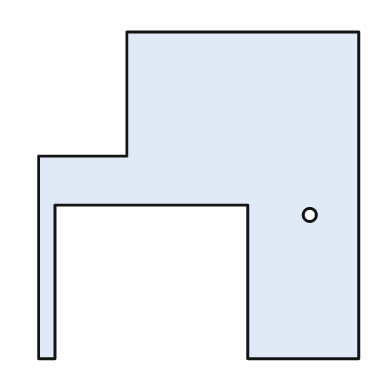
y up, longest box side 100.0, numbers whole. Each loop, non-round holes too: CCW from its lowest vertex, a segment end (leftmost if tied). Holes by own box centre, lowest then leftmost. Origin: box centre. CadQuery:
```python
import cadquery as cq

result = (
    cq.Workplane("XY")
    .moveTo(-49.0, -50.0)
    .lineTo(-44.0, -50.0)
    .lineTo(-44.0, -3.0)
    .lineTo(15.0, -3.0)
    .lineTo(15.0, -50.0)
    .lineTo(49.0, -50.0)
    .lineTo(49.0, 50.0)
    .lineTo(-22.0, 50.0)
    .lineTo(-22.0, 12.0)
    .lineTo(-49.0, 12.0)
    .close()
    .moveTo(34.0, -6.0)
    .circle(2.0)
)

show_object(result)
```